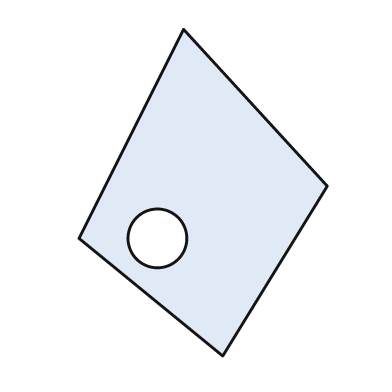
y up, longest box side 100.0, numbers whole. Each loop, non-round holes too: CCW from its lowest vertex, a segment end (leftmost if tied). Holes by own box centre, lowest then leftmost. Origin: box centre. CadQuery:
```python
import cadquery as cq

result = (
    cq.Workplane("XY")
    .moveTo(6.0, -50.0)
    .lineTo(38.0, 2.0)
    .lineTo(-6.0, 50.0)
    .lineTo(-38.0, -14.0)
    .close()
    .moveTo(-14.0, -14.0)
    .circle(9.0)
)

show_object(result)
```